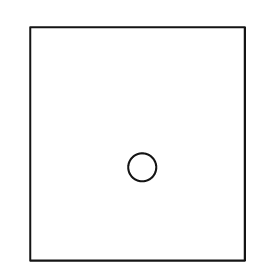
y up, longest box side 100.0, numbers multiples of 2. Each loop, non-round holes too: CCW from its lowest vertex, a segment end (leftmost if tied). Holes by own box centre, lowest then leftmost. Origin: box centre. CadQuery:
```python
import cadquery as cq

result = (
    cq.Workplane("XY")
    .moveTo(-46.0, -50.0)
    .lineTo(46.0, -50.0)
    .lineTo(46.0, 50.0)
    .lineTo(-46.0, 50.0)
    .close()
    .moveTo(2.0, -10.0)
    .circle(6.0)
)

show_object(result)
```